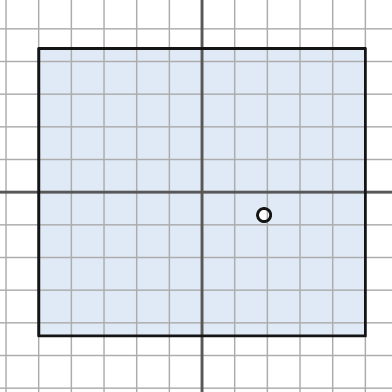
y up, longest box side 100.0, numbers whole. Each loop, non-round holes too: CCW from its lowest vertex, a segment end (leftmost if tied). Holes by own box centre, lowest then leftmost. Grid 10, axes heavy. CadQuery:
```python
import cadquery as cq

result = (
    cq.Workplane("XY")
    .moveTo(-50.0, -44.0)
    .lineTo(50.0, -44.0)
    .lineTo(50.0, 44.0)
    .lineTo(-50.0, 44.0)
    .close()
    .moveTo(19.0, -7.0)
    .circle(2.0)
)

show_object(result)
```